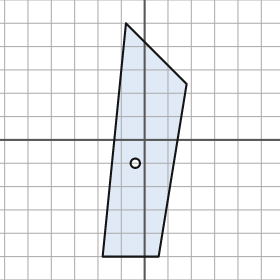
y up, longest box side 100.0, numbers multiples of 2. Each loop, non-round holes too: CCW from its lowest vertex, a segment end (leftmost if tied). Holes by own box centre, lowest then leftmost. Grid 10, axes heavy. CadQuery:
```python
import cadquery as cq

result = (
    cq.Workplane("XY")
    .moveTo(-18.0, -50.0)
    .lineTo(6.0, -50.0)
    .lineTo(18.0, 24.0)
    .lineTo(-8.0, 50.0)
    .close()
    .moveTo(-4.0, -10.0)
    .circle(2.0)
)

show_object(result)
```